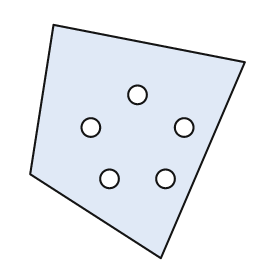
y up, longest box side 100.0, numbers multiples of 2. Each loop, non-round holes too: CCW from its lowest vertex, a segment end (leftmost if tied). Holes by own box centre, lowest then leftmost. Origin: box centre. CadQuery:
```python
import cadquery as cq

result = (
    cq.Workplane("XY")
    .moveTo(10.0, -50.0)
    .lineTo(46.0, 34.0)
    .lineTo(-36.0, 50.0)
    .lineTo(-46.0, -14.0)
    .close()
    .moveTo(-12.0, -16.0)
    .circle(4.0)
    .moveTo(12.0, -16.0)
    .circle(4.0)
    .moveTo(-20.0, 6.0)
    .circle(4.0)
    .moveTo(20.0, 6.0)
    .circle(4.0)
    .moveTo(0.0, 20.0)
    .circle(4.0)
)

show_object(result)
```